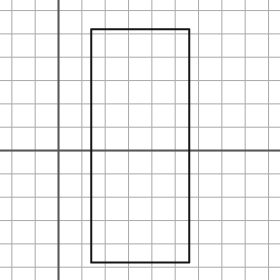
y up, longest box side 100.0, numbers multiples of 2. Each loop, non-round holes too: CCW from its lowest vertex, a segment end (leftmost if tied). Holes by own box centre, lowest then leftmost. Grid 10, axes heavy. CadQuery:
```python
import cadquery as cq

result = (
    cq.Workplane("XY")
    .moveTo(14.0, -48.0)
    .lineTo(56.0, -48.0)
    .lineTo(56.0, 52.0)
    .lineTo(14.0, 52.0)
    .close()
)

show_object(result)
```